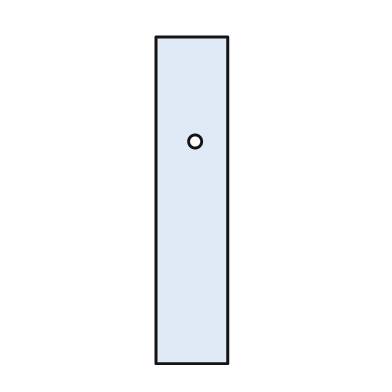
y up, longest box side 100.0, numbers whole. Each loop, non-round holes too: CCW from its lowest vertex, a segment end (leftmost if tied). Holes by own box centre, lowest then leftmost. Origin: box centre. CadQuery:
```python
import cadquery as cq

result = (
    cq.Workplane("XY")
    .moveTo(-11.0, -50.0)
    .lineTo(11.0, -50.0)
    .lineTo(11.0, 50.0)
    .lineTo(-11.0, 50.0)
    .close()
    .moveTo(1.0, 18.0)
    .circle(2.0)
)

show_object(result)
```